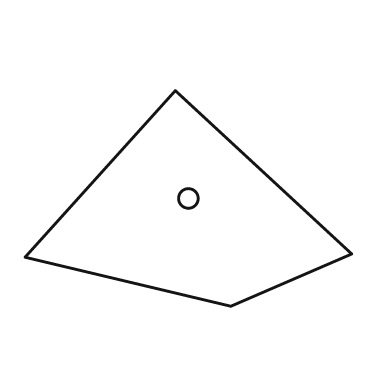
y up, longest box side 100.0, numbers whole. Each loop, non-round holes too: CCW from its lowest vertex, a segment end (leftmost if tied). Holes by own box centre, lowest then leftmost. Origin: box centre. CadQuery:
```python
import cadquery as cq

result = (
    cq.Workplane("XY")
    .moveTo(13.0, -33.0)
    .lineTo(50.0, -17.0)
    .lineTo(-4.0, 33.0)
    .lineTo(-50.0, -18.0)
    .close()
    .moveTo(0.0, 0.0)
    .circle(3.0)
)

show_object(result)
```